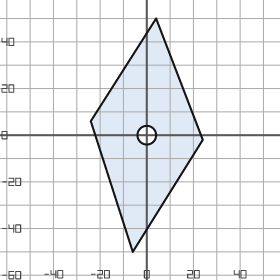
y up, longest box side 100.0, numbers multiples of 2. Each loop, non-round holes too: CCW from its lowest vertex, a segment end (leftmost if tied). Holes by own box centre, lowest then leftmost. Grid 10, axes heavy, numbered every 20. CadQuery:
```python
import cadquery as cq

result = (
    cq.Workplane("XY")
    .moveTo(-6.0, -50.0)
    .lineTo(24.0, -2.0)
    .lineTo(4.0, 50.0)
    .lineTo(-24.0, 6.0)
    .close()
    .moveTo(0.0, 0.0)
    .circle(4.0)
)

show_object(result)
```